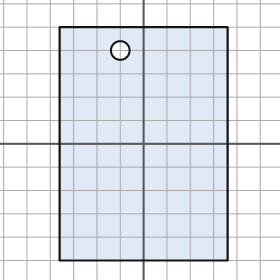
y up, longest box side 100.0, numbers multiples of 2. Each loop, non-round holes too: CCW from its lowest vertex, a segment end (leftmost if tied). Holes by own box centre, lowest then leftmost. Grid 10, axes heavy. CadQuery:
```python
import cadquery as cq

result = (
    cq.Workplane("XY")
    .moveTo(-36.0, -50.0)
    .lineTo(36.0, -50.0)
    .lineTo(36.0, 50.0)
    .lineTo(-36.0, 50.0)
    .close()
    .moveTo(-10.0, 40.0)
    .circle(4.0)
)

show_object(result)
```